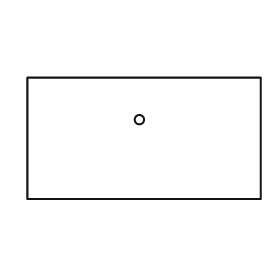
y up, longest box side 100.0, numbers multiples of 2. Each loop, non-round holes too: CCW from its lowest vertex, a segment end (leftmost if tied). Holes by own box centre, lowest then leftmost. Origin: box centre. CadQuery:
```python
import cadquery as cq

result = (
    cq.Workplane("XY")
    .moveTo(-50.0, -26.0)
    .lineTo(50.0, -26.0)
    .lineTo(50.0, 26.0)
    .lineTo(-50.0, 26.0)
    .close()
    .moveTo(-2.0, 8.0)
    .circle(2.0)
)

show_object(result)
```